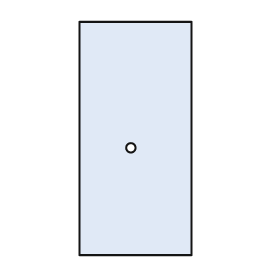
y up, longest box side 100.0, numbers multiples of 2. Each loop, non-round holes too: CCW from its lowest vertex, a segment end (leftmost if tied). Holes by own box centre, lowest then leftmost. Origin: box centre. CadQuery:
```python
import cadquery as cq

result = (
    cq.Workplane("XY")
    .moveTo(-24.0, -50.0)
    .lineTo(24.0, -50.0)
    .lineTo(24.0, 50.0)
    .lineTo(-24.0, 50.0)
    .close()
    .moveTo(-2.0, -4.0)
    .circle(2.0)
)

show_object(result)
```